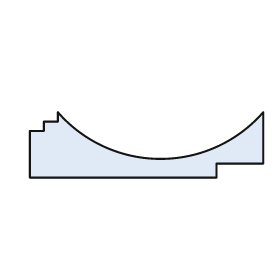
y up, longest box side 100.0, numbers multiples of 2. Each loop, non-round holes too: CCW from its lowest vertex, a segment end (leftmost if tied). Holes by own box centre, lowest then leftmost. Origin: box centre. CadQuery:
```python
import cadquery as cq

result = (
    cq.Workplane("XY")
    .moveTo(-50.0, -14.0)
    .lineTo(30.0, -14.0)
    .lineTo(30.0, -8.0)
    .lineTo(50.0, -8.0)
    .lineTo(50.0, 14.0)
    .threePointArc((6.0, -6.0), (-38.0, 14.0))
    .lineTo(-38.0, 10.0)
    .lineTo(-44.0, 10.0)
    .lineTo(-44.0, 6.0)
    .lineTo(-50.0, 6.0)
    .close()
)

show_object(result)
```